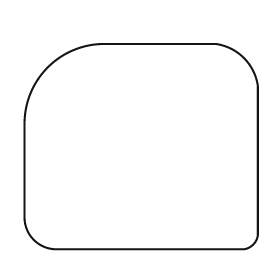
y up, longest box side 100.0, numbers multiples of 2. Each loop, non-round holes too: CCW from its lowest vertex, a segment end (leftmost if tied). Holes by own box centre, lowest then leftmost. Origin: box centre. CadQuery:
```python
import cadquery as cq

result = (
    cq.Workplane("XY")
    .moveTo(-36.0, -44.0)
    .lineTo(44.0, -44.0)
    .threePointArc((48.0, -42.0), (50.0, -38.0))
    .lineTo(50.0, 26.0)
    .threePointArc((44.0, 38.0), (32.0, 44.0))
    .lineTo(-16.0, 44.0)
    .threePointArc((-40.0, 34.0), (-50.0, 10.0))
    .lineTo(-50.0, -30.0)
    .threePointArc((-46.0, -40.0), (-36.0, -44.0))
    .close()
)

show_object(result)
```